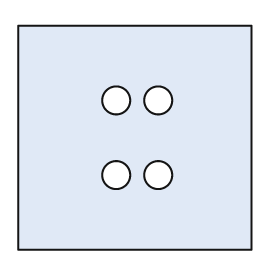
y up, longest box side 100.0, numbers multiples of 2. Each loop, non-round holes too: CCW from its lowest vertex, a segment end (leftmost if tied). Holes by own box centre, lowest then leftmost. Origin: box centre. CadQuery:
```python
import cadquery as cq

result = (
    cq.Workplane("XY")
    .moveTo(-50.0, -48.0)
    .lineTo(50.0, -48.0)
    .lineTo(50.0, 48.0)
    .lineTo(-50.0, 48.0)
    .close()
    .moveTo(-8.0, -16.0)
    .circle(6.0)
    .moveTo(10.0, -16.0)
    .circle(6.0)
    .moveTo(-8.0, 16.0)
    .circle(6.0)
    .moveTo(10.0, 16.0)
    .circle(6.0)
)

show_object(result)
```